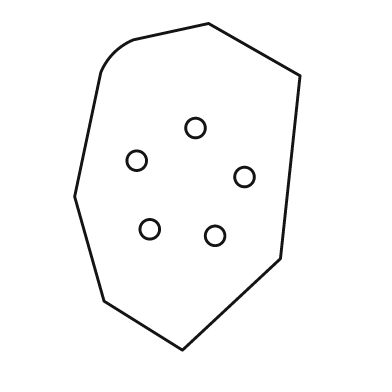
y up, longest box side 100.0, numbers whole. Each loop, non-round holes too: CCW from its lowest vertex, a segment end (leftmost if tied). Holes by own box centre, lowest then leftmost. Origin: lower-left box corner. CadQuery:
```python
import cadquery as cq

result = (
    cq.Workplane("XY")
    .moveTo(33.0, 0.0)
    .lineTo(63.0, 28.0)
    .lineTo(69.0, 84.0)
    .lineTo(41.0, 100.0)
    .lineTo(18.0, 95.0)
    .threePointArc((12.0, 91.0), (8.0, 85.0))
    .lineTo(0.0, 47.0)
    .lineTo(9.0, 15.0)
    .close()
    .moveTo(43.0, 35.0)
    .circle(3.0)
    .moveTo(23.0, 37.0)
    .circle(3.0)
    .moveTo(52.0, 53.0)
    .circle(3.0)
    .moveTo(19.0, 58.0)
    .circle(3.0)
    .moveTo(37.0, 68.0)
    .circle(3.0)
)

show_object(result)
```